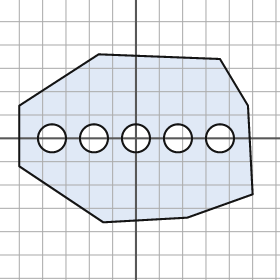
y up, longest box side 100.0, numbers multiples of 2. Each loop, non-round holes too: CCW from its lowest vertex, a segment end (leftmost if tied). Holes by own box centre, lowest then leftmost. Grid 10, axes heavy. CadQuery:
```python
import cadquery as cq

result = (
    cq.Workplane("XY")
    .moveTo(-14.0, -36.0)
    .lineTo(22.0, -34.0)
    .lineTo(50.0, -24.0)
    .lineTo(48.0, 14.0)
    .lineTo(36.0, 34.0)
    .lineTo(-16.0, 36.0)
    .lineTo(-50.0, 14.0)
    .lineTo(-50.0, -12.0)
    .close()
    .moveTo(-36.0, 0.0)
    .circle(6.0)
    .moveTo(-18.0, 0.0)
    .circle(6.0)
    .moveTo(0.0, 0.0)
    .circle(6.0)
    .moveTo(18.0, 0.0)
    .circle(6.0)
    .moveTo(36.0, 0.0)
    .circle(6.0)
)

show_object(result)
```